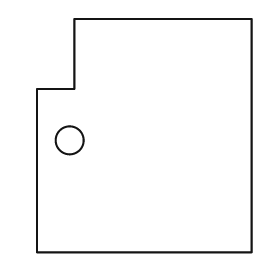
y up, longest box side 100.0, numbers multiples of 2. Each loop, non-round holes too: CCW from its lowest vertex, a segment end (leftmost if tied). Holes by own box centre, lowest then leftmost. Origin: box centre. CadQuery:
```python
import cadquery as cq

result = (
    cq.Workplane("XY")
    .moveTo(-46.0, -50.0)
    .lineTo(46.0, -50.0)
    .lineTo(46.0, 50.0)
    .lineTo(-30.0, 50.0)
    .lineTo(-30.0, 20.0)
    .lineTo(-46.0, 20.0)
    .close()
    .moveTo(-32.0, -2.0)
    .circle(6.0)
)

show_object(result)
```